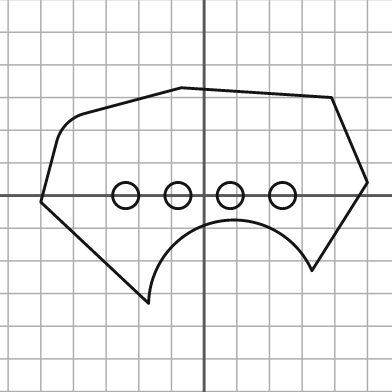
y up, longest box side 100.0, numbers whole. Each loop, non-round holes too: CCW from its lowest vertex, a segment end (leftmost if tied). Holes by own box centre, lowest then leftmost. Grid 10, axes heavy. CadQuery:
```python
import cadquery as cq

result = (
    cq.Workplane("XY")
    .moveTo(-17.0, -33.0)
    .threePointArc((4.0, -8.0), (33.0, -23.0))
    .lineTo(50.0, 4.0)
    .lineTo(39.0, 30.0)
    .lineTo(-7.0, 33.0)
    .lineTo(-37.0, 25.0)
    .threePointArc((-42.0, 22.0), (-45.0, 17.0))
    .lineTo(-50.0, -2.0)
    .close()
    .moveTo(-24.0, 0.0)
    .circle(4.0)
    .moveTo(-8.0, 0.0)
    .circle(4.0)
    .moveTo(8.0, 0.0)
    .circle(4.0)
    .moveTo(24.0, 0.0)
    .circle(4.0)
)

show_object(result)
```